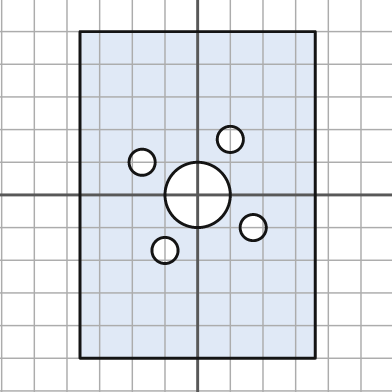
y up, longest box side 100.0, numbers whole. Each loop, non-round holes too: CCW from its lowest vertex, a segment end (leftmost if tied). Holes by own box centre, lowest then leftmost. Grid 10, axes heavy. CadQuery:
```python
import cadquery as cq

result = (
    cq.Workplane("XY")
    .moveTo(-36.0, -50.0)
    .lineTo(36.0, -50.0)
    .lineTo(36.0, 50.0)
    .lineTo(-36.0, 50.0)
    .close()
    .moveTo(-10.0, -17.0)
    .circle(4.0)
    .moveTo(17.0, -10.0)
    .circle(4.0)
    .moveTo(0.0, 0.0)
    .circle(10.0)
    .moveTo(-17.0, 10.0)
    .circle(4.0)
    .moveTo(10.0, 17.0)
    .circle(4.0)
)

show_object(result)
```